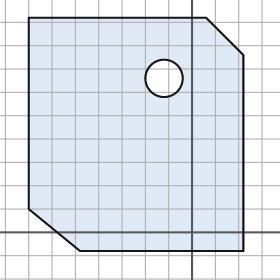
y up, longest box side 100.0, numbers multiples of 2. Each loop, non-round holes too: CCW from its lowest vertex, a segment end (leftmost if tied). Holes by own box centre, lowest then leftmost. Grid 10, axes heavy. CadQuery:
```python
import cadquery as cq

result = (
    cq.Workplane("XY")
    .moveTo(-48.0, -8.0)
    .lineTo(22.0, -8.0)
    .lineTo(22.0, 76.0)
    .lineTo(6.0, 92.0)
    .lineTo(-70.0, 92.0)
    .lineTo(-70.0, 10.0)
    .close()
    .moveTo(-12.0, 66.0)
    .circle(8.0)
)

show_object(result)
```